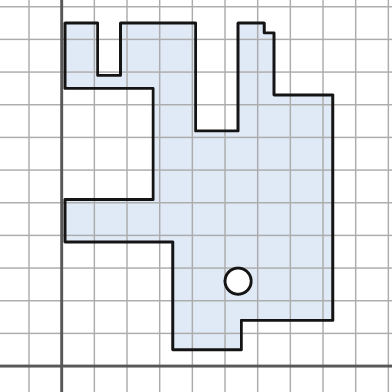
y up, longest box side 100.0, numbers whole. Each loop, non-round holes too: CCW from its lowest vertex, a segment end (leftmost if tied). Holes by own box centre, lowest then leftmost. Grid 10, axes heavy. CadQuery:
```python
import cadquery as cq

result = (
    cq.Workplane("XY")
    .moveTo(34.0, 5.0)
    .lineTo(55.0, 5.0)
    .lineTo(55.0, 14.0)
    .lineTo(83.0, 14.0)
    .lineTo(83.0, 83.0)
    .lineTo(65.0, 83.0)
    .lineTo(65.0, 102.0)
    .lineTo(62.0, 102.0)
    .lineTo(62.0, 105.0)
    .lineTo(54.0, 105.0)
    .lineTo(54.0, 72.0)
    .lineTo(41.0, 72.0)
    .lineTo(41.0, 105.0)
    .lineTo(18.0, 105.0)
    .lineTo(18.0, 89.0)
    .lineTo(11.0, 89.0)
    .lineTo(11.0, 105.0)
    .lineTo(1.0, 105.0)
    .lineTo(1.0, 85.0)
    .lineTo(28.0, 85.0)
    .lineTo(28.0, 51.0)
    .lineTo(1.0, 51.0)
    .lineTo(1.0, 38.0)
    .lineTo(34.0, 38.0)
    .close()
    .moveTo(54.0, 26.0)
    .circle(4.0)
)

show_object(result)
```